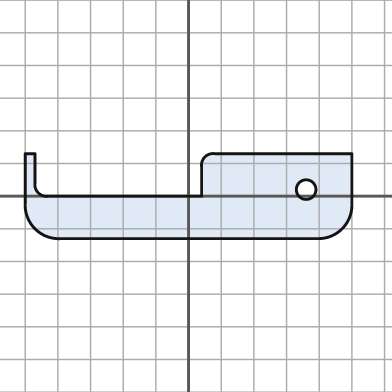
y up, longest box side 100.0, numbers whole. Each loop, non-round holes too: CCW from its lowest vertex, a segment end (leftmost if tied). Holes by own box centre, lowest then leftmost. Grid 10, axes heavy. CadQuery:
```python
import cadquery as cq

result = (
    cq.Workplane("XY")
    .moveTo(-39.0, -13.0)
    .lineTo(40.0, -13.0)
    .threePointArc((47.0, -10.0), (50.0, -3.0))
    .lineTo(50.0, 13.0)
    .lineTo(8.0, 13.0)
    .threePointArc((5.0, 12.0), (4.0, 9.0))
    .lineTo(4.0, 0.0)
    .lineTo(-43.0, 0.0)
    .threePointArc((-46.0, 1.0), (-47.0, 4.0))
    .lineTo(-47.0, 13.0)
    .lineTo(-50.0, 13.0)
    .lineTo(-50.0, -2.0)
    .threePointArc((-47.0, -10.0), (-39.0, -13.0))
    .close()
    .moveTo(36.0, 2.0)
    .circle(3.0)
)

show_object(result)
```